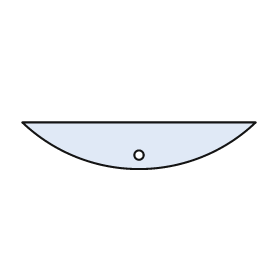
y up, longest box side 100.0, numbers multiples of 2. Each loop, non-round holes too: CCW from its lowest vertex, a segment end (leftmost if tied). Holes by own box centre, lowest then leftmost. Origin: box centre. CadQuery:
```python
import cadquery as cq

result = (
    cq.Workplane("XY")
    .moveTo(-50.0, 10.0)
    .threePointArc((0.0, -10.0), (50.0, 10.0))
    .close()
    .moveTo(0.0, -4.0)
    .circle(2.0)
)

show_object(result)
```